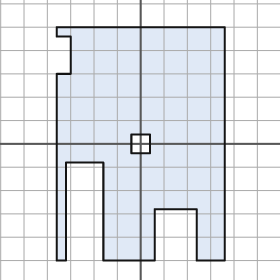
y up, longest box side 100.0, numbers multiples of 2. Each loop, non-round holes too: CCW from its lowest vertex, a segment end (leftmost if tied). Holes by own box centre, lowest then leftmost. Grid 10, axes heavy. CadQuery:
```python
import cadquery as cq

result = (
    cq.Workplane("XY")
    .moveTo(-36.0, -50.0)
    .lineTo(-32.0, -50.0)
    .lineTo(-32.0, -8.0)
    .lineTo(-16.0, -8.0)
    .lineTo(-16.0, -50.0)
    .lineTo(6.0, -50.0)
    .lineTo(6.0, -28.0)
    .lineTo(24.0, -28.0)
    .lineTo(24.0, -50.0)
    .lineTo(36.0, -50.0)
    .lineTo(36.0, 50.0)
    .lineTo(-36.0, 50.0)
    .lineTo(-36.0, 46.0)
    .lineTo(-30.0, 46.0)
    .lineTo(-30.0, 30.0)
    .lineTo(-36.0, 30.0)
    .close()
    .moveTo(-4.0, -4.0)
    .lineTo(4.0, -4.0)
    .lineTo(4.0, 4.0)
    .lineTo(-4.0, 4.0)
    .close()
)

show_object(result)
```